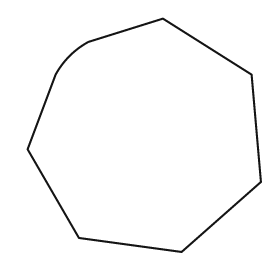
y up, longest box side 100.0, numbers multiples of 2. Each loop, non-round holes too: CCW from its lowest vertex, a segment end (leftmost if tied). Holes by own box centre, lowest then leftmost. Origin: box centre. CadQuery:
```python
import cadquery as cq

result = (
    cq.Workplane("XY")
    .moveTo(16.0, -50.0)
    .lineTo(50.0, -20.0)
    .lineTo(46.0, 26.0)
    .lineTo(8.0, 50.0)
    .lineTo(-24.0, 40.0)
    .threePointArc((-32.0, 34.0), (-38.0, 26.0))
    .lineTo(-50.0, -6.0)
    .lineTo(-28.0, -44.0)
    .close()
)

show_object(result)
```